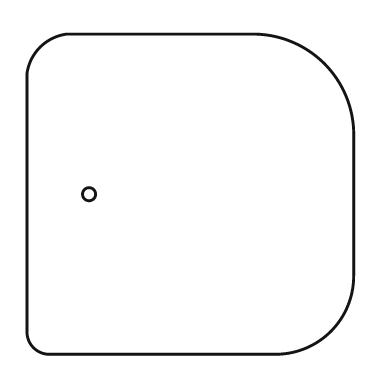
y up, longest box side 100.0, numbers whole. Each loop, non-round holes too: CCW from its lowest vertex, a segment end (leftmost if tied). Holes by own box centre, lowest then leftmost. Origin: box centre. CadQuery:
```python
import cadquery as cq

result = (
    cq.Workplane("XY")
    .moveTo(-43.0, -49.0)
    .lineTo(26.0, -49.0)
    .threePointArc((43.0, -42.0), (50.0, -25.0))
    .lineTo(50.0, 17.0)
    .threePointArc((41.0, 40.0), (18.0, 49.0))
    .lineTo(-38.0, 49.0)
    .threePointArc((-46.0, 45.0), (-50.0, 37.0))
    .lineTo(-50.0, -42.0)
    .threePointArc((-48.0, -47.0), (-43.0, -49.0))
    .close()
    .moveTo(-31.0, 0.0)
    .circle(2.0)
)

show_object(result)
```